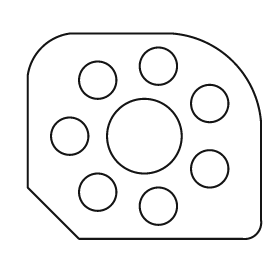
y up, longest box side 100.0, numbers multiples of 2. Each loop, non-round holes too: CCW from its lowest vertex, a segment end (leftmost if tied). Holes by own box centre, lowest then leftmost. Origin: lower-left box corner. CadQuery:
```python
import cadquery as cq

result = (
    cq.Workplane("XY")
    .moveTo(22.0, 0.0)
    .lineTo(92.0, 0.0)
    .threePointArc((98.0, 2.0), (100.0, 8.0))
    .lineTo(100.0, 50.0)
    .threePointArc((88.0, 76.0), (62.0, 88.0))
    .lineTo(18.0, 88.0)
    .threePointArc((6.0, 82.0), (0.0, 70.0))
    .lineTo(0.0, 22.0)
    .close()
    .moveTo(56.0, 14.0)
    .circle(8.0)
    .moveTo(30.0, 20.0)
    .circle(8.0)
    .moveTo(78.0, 30.0)
    .circle(8.0)
    .moveTo(18.0, 44.0)
    .circle(8.0)
    .moveTo(50.0, 44.0)
    .circle(16.0)
    .moveTo(78.0, 58.0)
    .circle(8.0)
    .moveTo(30.0, 68.0)
    .circle(8.0)
    .moveTo(56.0, 74.0)
    .circle(8.0)
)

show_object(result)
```